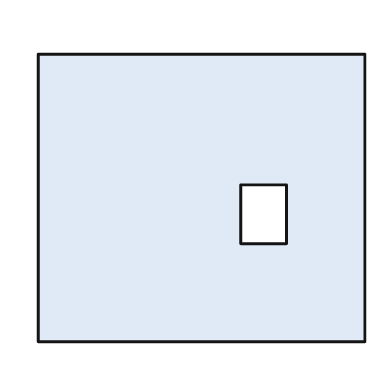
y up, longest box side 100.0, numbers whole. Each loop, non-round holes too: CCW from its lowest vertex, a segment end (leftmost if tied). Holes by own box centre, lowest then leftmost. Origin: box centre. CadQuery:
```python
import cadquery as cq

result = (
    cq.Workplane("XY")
    .moveTo(-50.0, -44.0)
    .lineTo(50.0, -44.0)
    .lineTo(50.0, 44.0)
    .lineTo(-50.0, 44.0)
    .close()
    .moveTo(12.0, -14.0)
    .lineTo(26.0, -14.0)
    .lineTo(26.0, 4.0)
    .lineTo(12.0, 4.0)
    .close()
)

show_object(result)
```